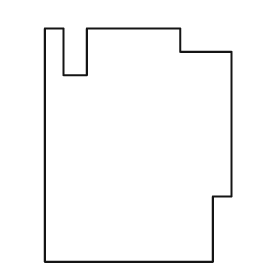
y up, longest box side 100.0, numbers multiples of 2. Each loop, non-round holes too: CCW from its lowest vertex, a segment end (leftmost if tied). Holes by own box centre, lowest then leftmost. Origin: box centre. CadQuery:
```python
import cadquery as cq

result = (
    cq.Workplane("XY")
    .moveTo(-40.0, -50.0)
    .lineTo(32.0, -50.0)
    .lineTo(32.0, -22.0)
    .lineTo(40.0, -22.0)
    .lineTo(40.0, 40.0)
    .lineTo(18.0, 40.0)
    .lineTo(18.0, 50.0)
    .lineTo(-22.0, 50.0)
    .lineTo(-22.0, 30.0)
    .lineTo(-32.0, 30.0)
    .lineTo(-32.0, 50.0)
    .lineTo(-40.0, 50.0)
    .close()
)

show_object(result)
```